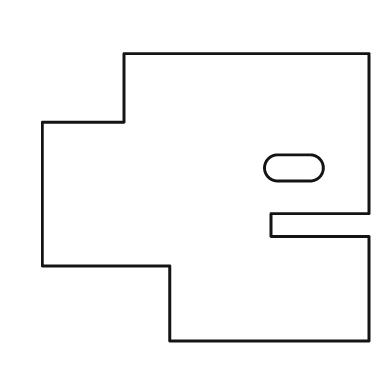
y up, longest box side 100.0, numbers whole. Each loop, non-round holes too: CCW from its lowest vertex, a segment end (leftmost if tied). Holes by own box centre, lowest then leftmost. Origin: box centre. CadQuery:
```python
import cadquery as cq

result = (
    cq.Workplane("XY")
    .moveTo(-11.0, -44.0)
    .lineTo(50.0, -44.0)
    .lineTo(50.0, -12.0)
    .lineTo(20.0, -12.0)
    .lineTo(20.0, -5.0)
    .lineTo(50.0, -5.0)
    .lineTo(50.0, 44.0)
    .lineTo(-25.0, 44.0)
    .lineTo(-25.0, 23.0)
    .lineTo(-50.0, 23.0)
    .lineTo(-50.0, -21.0)
    .lineTo(-11.0, -21.0)
    .close()
    .moveTo(22.0, 5.0)
    .lineTo(32.0, 5.0)
    .threePointArc((36.0, 9.0), (32.0, 13.0))
    .lineTo(22.0, 13.0)
    .threePointArc((18.0, 9.0), (22.0, 5.0))
    .close()
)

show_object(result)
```